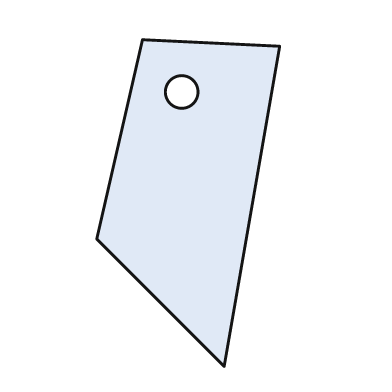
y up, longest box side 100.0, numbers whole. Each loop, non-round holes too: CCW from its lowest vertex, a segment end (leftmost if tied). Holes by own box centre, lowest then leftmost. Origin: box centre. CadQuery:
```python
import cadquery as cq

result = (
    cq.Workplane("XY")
    .moveTo(11.0, -50.0)
    .lineTo(28.0, 48.0)
    .lineTo(-14.0, 50.0)
    .lineTo(-28.0, -11.0)
    .close()
    .moveTo(-2.0, 34.0)
    .circle(5.0)
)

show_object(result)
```